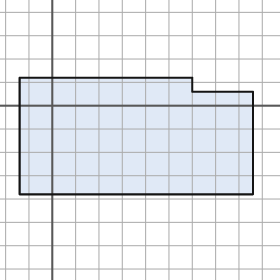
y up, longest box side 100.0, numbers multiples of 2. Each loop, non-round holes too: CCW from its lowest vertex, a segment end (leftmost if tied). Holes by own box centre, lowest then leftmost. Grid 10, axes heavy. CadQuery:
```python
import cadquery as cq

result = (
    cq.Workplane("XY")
    .moveTo(-14.0, -38.0)
    .lineTo(86.0, -38.0)
    .lineTo(86.0, 6.0)
    .lineTo(60.0, 6.0)
    .lineTo(60.0, 12.0)
    .lineTo(-14.0, 12.0)
    .close()
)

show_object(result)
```